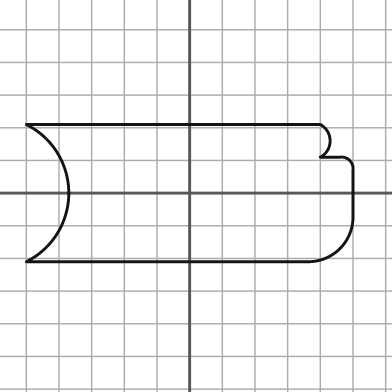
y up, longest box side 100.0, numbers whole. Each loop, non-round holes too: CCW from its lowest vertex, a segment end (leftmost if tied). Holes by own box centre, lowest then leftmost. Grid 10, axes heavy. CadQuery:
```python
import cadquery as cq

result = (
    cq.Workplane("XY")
    .moveTo(-50.0, -21.0)
    .lineTo(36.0, -21.0)
    .threePointArc((46.0, -17.0), (50.0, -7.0))
    .lineTo(50.0, 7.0)
    .threePointArc((49.0, 10.0), (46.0, 11.0))
    .lineTo(40.0, 11.0)
    .threePointArc((43.0, 16.0), (40.0, 21.0))
    .lineTo(-50.0, 21.0)
    .threePointArc((-37.0, 0.0), (-50.0, -21.0))
    .close()
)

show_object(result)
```